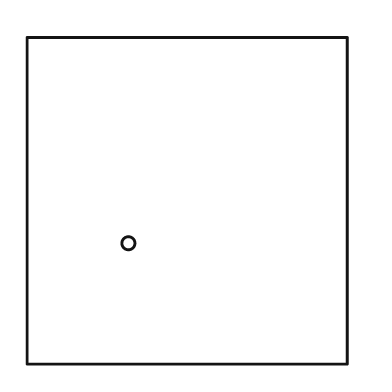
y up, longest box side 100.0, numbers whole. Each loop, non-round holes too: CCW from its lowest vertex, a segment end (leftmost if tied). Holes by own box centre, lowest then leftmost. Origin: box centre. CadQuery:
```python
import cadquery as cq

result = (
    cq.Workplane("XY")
    .moveTo(-49.0, -50.0)
    .lineTo(49.0, -50.0)
    .lineTo(49.0, 50.0)
    .lineTo(-49.0, 50.0)
    .close()
    .moveTo(-18.0, -13.0)
    .circle(2.0)
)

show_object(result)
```